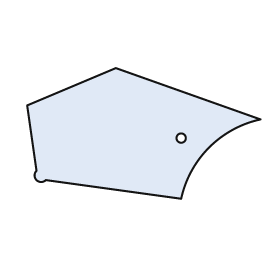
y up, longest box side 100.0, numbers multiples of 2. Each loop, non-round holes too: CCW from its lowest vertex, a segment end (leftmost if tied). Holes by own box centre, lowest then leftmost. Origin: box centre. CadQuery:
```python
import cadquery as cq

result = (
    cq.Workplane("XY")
    .moveTo(16.0, -28.0)
    .threePointArc((28.0, -6.0), (50.0, 6.0))
    .lineTo(-12.0, 28.0)
    .lineTo(-50.0, 12.0)
    .lineTo(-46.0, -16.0)
    .threePointArc((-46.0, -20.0), (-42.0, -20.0))
    .close()
    .moveTo(16.0, -2.0)
    .circle(2.0)
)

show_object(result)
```